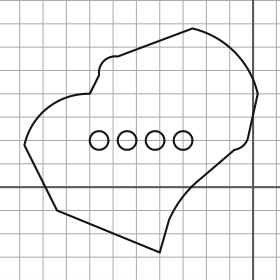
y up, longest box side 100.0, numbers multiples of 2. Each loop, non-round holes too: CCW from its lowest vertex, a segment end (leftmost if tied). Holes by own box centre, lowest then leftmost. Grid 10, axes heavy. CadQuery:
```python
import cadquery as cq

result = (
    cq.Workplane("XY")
    .moveTo(-40.0, -28.0)
    .lineTo(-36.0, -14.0)
    .threePointArc((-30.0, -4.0), (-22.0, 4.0))
    .lineTo(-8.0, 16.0)
    .threePointArc((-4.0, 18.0), (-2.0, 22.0))
    .lineTo(2.0, 40.0)
    .threePointArc((-8.0, 58.0), (-26.0, 68.0))
    .lineTo(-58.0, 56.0)
    .threePointArc((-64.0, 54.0), (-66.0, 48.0))
    .lineTo(-70.0, 40.0)
    .threePointArc((-88.0, 34.0), (-98.0, 18.0))
    .lineTo(-84.0, -10.0)
    .close()
    .moveTo(-66.0, 20.0)
    .circle(4.0)
    .moveTo(-54.0, 20.0)
    .circle(4.0)
    .moveTo(-42.0, 20.0)
    .circle(4.0)
    .moveTo(-30.0, 20.0)
    .circle(4.0)
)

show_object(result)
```